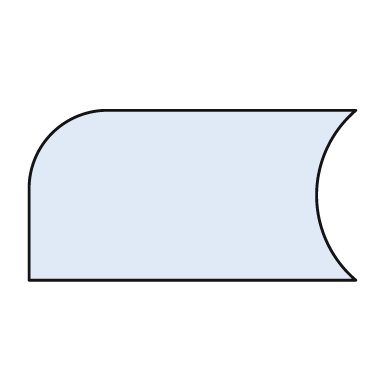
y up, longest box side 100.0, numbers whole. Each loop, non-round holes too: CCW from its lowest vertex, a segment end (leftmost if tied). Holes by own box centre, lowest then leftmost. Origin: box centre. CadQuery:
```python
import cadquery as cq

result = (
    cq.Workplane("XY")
    .moveTo(-50.0, -26.0)
    .lineTo(50.0, -26.0)
    .threePointArc((38.0, 0.0), (50.0, 26.0))
    .lineTo(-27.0, 26.0)
    .threePointArc((-43.0, 19.0), (-50.0, 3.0))
    .close()
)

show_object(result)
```